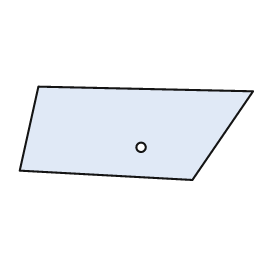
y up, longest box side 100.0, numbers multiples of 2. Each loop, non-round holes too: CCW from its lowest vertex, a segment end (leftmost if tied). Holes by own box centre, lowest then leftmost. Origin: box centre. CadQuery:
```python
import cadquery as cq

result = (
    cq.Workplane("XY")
    .moveTo(24.0, -20.0)
    .lineTo(50.0, 18.0)
    .lineTo(-42.0, 20.0)
    .lineTo(-50.0, -16.0)
    .close()
    .moveTo(2.0, -6.0)
    .circle(2.0)
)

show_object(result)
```